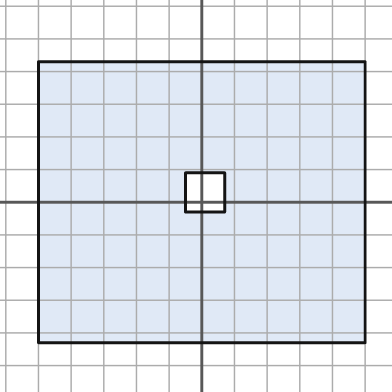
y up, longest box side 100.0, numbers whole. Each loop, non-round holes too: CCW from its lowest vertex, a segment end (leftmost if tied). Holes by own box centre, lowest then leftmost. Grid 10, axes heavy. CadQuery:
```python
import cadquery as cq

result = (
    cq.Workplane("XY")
    .moveTo(-50.0, -43.0)
    .lineTo(50.0, -43.0)
    .lineTo(50.0, 43.0)
    .lineTo(-50.0, 43.0)
    .close()
    .moveTo(-5.0, -3.0)
    .lineTo(7.0, -3.0)
    .lineTo(7.0, 9.0)
    .lineTo(-5.0, 9.0)
    .close()
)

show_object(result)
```